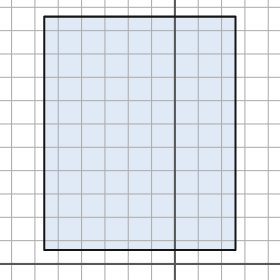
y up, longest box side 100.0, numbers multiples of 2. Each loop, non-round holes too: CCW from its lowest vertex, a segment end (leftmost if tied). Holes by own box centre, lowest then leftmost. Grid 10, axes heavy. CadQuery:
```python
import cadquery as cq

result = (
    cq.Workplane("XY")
    .moveTo(-56.0, 6.0)
    .lineTo(26.0, 6.0)
    .lineTo(26.0, 106.0)
    .lineTo(-56.0, 106.0)
    .close()
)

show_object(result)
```